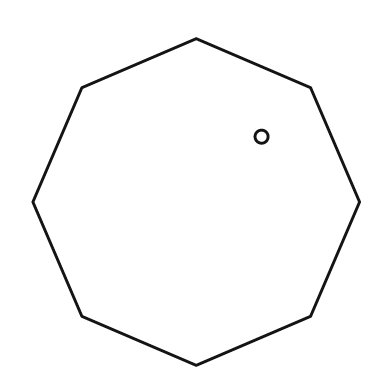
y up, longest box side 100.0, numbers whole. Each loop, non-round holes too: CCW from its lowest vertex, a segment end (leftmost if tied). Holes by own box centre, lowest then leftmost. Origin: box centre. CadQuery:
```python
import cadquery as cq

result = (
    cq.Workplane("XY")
    .moveTo(0.0, -50.0)
    .lineTo(35.0, -35.0)
    .lineTo(50.0, 0.0)
    .lineTo(35.0, 35.0)
    .lineTo(0.0, 50.0)
    .lineTo(-35.0, 35.0)
    .lineTo(-50.0, 0.0)
    .lineTo(-35.0, -35.0)
    .close()
    .moveTo(20.0, 20.0)
    .circle(2.0)
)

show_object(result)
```